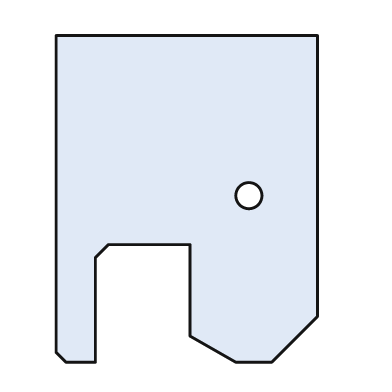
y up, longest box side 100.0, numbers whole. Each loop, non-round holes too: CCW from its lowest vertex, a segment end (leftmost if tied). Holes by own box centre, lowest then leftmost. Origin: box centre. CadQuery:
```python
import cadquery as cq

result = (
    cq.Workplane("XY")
    .moveTo(-37.0, -50.0)
    .lineTo(-28.0, -50.0)
    .lineTo(-28.0, -18.0)
    .lineTo(-24.0, -14.0)
    .lineTo(1.0, -14.0)
    .lineTo(1.0, -42.0)
    .lineTo(15.0, -50.0)
    .lineTo(26.0, -50.0)
    .lineTo(40.0, -36.0)
    .lineTo(40.0, 50.0)
    .lineTo(-40.0, 50.0)
    .lineTo(-40.0, -47.0)
    .close()
    .moveTo(19.0, 1.0)
    .circle(4.0)
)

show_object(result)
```